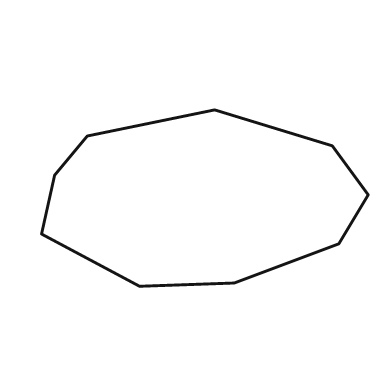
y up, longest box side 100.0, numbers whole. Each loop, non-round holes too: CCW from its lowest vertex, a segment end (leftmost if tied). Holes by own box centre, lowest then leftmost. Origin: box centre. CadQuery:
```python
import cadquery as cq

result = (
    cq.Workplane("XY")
    .moveTo(-20.0, -27.0)
    .lineTo(9.0, -26.0)
    .lineTo(41.0, -14.0)
    .lineTo(50.0, 1.0)
    .lineTo(39.0, 16.0)
    .lineTo(3.0, 27.0)
    .lineTo(-36.0, 19.0)
    .lineTo(-46.0, 7.0)
    .lineTo(-50.0, -11.0)
    .close()
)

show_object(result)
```